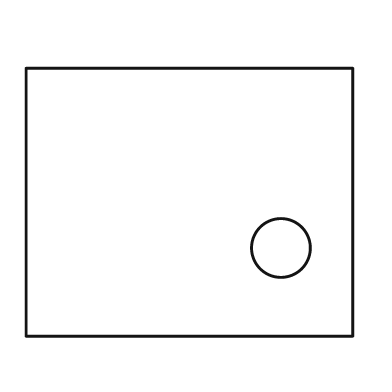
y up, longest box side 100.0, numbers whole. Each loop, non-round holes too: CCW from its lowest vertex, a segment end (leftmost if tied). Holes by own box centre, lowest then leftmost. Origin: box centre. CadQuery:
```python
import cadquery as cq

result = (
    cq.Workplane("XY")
    .moveTo(-50.0, -41.0)
    .lineTo(50.0, -41.0)
    .lineTo(50.0, 41.0)
    .lineTo(-50.0, 41.0)
    .close()
    .moveTo(28.0, -14.0)
    .circle(9.0)
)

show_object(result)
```